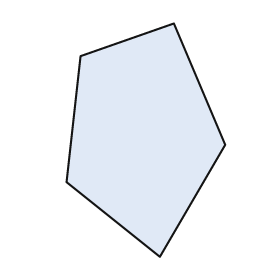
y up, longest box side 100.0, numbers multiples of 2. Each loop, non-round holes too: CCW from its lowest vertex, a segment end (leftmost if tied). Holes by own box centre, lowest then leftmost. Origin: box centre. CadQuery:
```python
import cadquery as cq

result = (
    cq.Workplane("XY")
    .moveTo(6.0, -50.0)
    .lineTo(34.0, -2.0)
    .lineTo(12.0, 50.0)
    .lineTo(-28.0, 36.0)
    .lineTo(-34.0, -18.0)
    .close()
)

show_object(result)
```